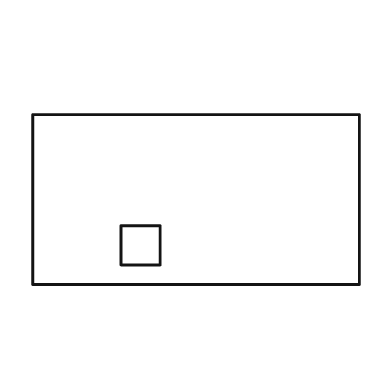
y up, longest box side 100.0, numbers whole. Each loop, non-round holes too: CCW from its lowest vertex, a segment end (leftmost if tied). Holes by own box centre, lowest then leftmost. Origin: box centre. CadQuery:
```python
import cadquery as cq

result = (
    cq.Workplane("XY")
    .moveTo(-50.0, -26.0)
    .lineTo(50.0, -26.0)
    .lineTo(50.0, 26.0)
    .lineTo(-50.0, 26.0)
    .close()
    .moveTo(-23.0, -20.0)
    .lineTo(-11.0, -20.0)
    .lineTo(-11.0, -8.0)
    .lineTo(-23.0, -8.0)
    .close()
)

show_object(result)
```